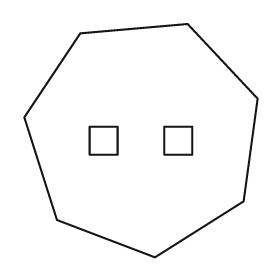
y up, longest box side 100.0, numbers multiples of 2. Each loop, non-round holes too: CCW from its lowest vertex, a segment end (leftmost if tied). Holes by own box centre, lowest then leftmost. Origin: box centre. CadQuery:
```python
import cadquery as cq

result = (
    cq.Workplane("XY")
    .moveTo(6.0, -50.0)
    .lineTo(44.0, -26.0)
    .lineTo(50.0, 18.0)
    .lineTo(20.0, 50.0)
    .lineTo(-26.0, 46.0)
    .lineTo(-50.0, 10.0)
    .lineTo(-36.0, -34.0)
    .close()
    .moveTo(-22.0, -6.0)
    .lineTo(-10.0, -6.0)
    .lineTo(-10.0, 6.0)
    .lineTo(-22.0, 6.0)
    .close()
    .moveTo(10.0, -6.0)
    .lineTo(22.0, -6.0)
    .lineTo(22.0, 6.0)
    .lineTo(10.0, 6.0)
    .close()
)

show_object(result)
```